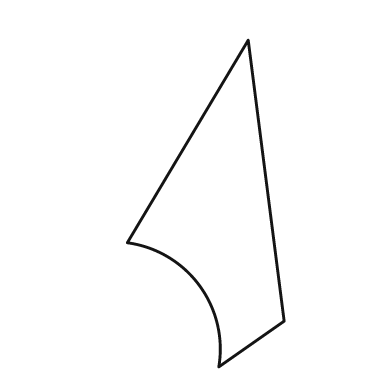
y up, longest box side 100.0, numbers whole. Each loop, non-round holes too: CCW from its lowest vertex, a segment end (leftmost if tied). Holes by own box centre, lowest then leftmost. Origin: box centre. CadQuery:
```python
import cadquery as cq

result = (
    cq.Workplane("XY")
    .moveTo(4.0, -50.0)
    .lineTo(24.0, -36.0)
    .lineTo(13.0, 50.0)
    .lineTo(-24.0, -12.0)
    .threePointArc((-2.0, -25.0), (4.0, -50.0))
    .close()
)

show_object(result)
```